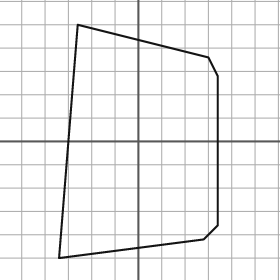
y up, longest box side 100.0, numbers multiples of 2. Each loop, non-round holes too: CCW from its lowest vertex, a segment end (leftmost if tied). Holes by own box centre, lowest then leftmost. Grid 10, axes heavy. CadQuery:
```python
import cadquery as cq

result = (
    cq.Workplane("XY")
    .moveTo(-34.0, -50.0)
    .lineTo(28.0, -42.0)
    .lineTo(34.0, -36.0)
    .lineTo(34.0, 28.0)
    .lineTo(30.0, 36.0)
    .lineTo(-26.0, 50.0)
    .close()
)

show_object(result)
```